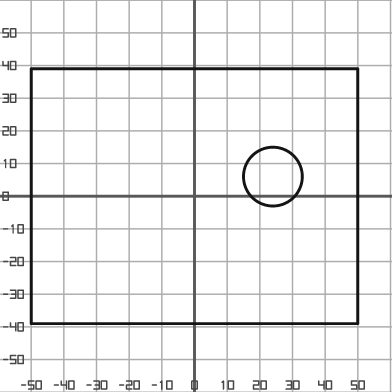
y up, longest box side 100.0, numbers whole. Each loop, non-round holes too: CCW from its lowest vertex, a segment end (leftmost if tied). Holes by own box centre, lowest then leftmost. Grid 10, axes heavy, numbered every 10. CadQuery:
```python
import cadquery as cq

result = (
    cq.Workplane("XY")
    .moveTo(-50.0, -39.0)
    .lineTo(50.0, -39.0)
    .lineTo(50.0, 39.0)
    .lineTo(-50.0, 39.0)
    .close()
    .moveTo(24.0, 6.0)
    .circle(9.0)
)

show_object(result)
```